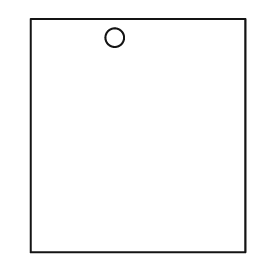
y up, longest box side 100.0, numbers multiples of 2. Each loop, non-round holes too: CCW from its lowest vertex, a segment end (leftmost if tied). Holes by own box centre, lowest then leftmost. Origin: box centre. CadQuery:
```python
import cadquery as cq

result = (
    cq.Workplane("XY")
    .moveTo(-46.0, -50.0)
    .lineTo(46.0, -50.0)
    .lineTo(46.0, 50.0)
    .lineTo(-46.0, 50.0)
    .close()
    .moveTo(-10.0, 42.0)
    .circle(4.0)
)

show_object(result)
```